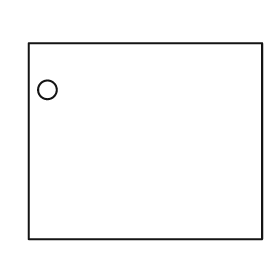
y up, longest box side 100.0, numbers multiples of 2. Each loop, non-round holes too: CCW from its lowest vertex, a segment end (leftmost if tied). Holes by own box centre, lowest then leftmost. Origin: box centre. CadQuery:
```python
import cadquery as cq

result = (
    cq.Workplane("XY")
    .moveTo(-50.0, -42.0)
    .lineTo(50.0, -42.0)
    .lineTo(50.0, 42.0)
    .lineTo(-50.0, 42.0)
    .close()
    .moveTo(-42.0, 22.0)
    .circle(4.0)
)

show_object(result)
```